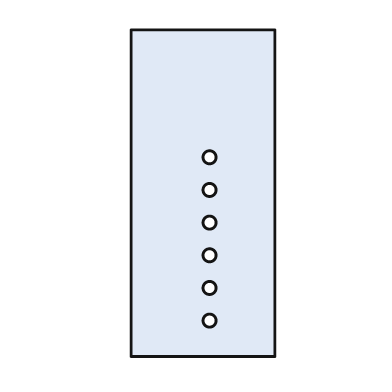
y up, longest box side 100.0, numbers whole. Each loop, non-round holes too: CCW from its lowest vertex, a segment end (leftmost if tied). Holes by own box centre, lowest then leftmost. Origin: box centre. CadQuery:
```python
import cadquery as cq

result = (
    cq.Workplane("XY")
    .moveTo(-22.0, -50.0)
    .lineTo(22.0, -50.0)
    .lineTo(22.0, 50.0)
    .lineTo(-22.0, 50.0)
    .close()
    .moveTo(2.0, -39.0)
    .circle(2.0)
    .moveTo(2.0, -29.0)
    .circle(2.0)
    .moveTo(2.0, -19.0)
    .circle(2.0)
    .moveTo(2.0, -9.0)
    .circle(2.0)
    .moveTo(2.0, 1.0)
    .circle(2.0)
    .moveTo(2.0, 11.0)
    .circle(2.0)
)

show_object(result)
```